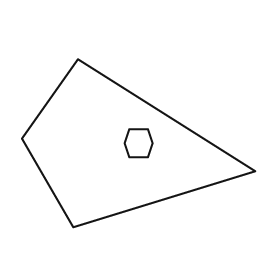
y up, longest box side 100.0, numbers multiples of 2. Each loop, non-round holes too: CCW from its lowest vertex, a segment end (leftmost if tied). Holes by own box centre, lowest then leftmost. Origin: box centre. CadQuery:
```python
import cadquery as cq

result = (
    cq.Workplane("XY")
    .moveTo(-28.0, -36.0)
    .lineTo(50.0, -12.0)
    .lineTo(-26.0, 36.0)
    .lineTo(-50.0, 2.0)
    .close()
    .moveTo(-4.0, -6.0)
    .lineTo(4.0, -6.0)
    .lineTo(6.0, 0.0)
    .lineTo(4.0, 6.0)
    .lineTo(-4.0, 6.0)
    .lineTo(-6.0, 0.0)
    .close()
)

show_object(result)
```